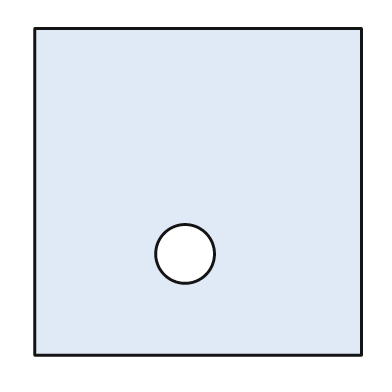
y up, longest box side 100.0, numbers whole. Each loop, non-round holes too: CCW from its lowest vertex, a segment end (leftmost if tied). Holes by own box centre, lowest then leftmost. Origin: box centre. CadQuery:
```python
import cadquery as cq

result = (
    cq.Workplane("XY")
    .moveTo(-50.0, -50.0)
    .lineTo(50.0, -50.0)
    .lineTo(50.0, 50.0)
    .lineTo(-50.0, 50.0)
    .close()
    .moveTo(-4.0, -19.0)
    .circle(9.0)
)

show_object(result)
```